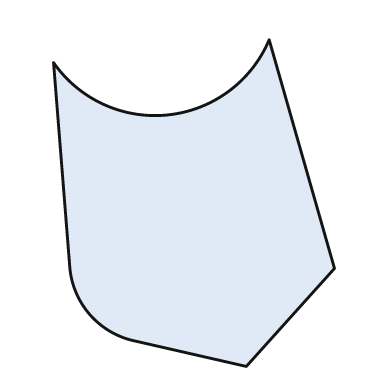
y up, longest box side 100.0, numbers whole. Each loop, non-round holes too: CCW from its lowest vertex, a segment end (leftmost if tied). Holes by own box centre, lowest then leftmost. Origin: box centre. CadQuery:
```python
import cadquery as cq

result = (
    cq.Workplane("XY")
    .moveTo(16.0, -50.0)
    .lineTo(43.0, -20.0)
    .lineTo(23.0, 50.0)
    .threePointArc((-8.0, 27.0), (-43.0, 43.0))
    .lineTo(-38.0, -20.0)
    .threePointArc((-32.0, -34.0), (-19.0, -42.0))
    .close()
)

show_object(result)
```